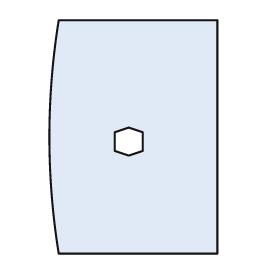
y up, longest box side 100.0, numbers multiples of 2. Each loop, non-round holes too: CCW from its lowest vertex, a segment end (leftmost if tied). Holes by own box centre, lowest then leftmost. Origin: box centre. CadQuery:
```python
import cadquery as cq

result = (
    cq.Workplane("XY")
    .moveTo(-32.0, -50.0)
    .lineTo(36.0, -50.0)
    .lineTo(36.0, 50.0)
    .lineTo(-32.0, 50.0)
    .threePointArc((-36.0, 0.0), (-32.0, -50.0))
    .close()
    .moveTo(-2.0, -8.0)
    .lineTo(4.0, -6.0)
    .lineTo(4.0, 2.0)
    .lineTo(-2.0, 4.0)
    .lineTo(-8.0, 2.0)
    .lineTo(-8.0, -6.0)
    .close()
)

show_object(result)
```